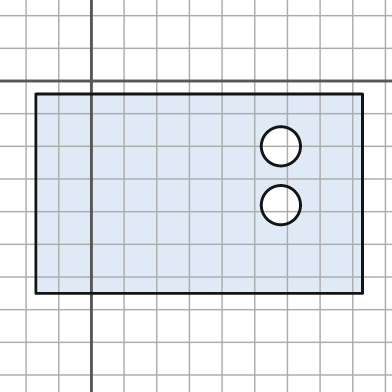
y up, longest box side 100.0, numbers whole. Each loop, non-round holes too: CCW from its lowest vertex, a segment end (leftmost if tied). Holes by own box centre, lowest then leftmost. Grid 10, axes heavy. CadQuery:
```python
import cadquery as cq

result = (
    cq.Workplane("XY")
    .moveTo(-17.0, -65.0)
    .lineTo(83.0, -65.0)
    .lineTo(83.0, -4.0)
    .lineTo(-17.0, -4.0)
    .close()
    .moveTo(58.0, -38.0)
    .circle(6.0)
    .moveTo(58.0, -20.0)
    .circle(6.0)
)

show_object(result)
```